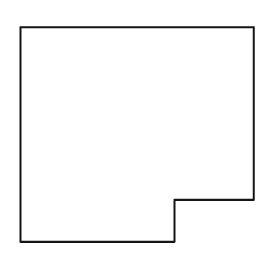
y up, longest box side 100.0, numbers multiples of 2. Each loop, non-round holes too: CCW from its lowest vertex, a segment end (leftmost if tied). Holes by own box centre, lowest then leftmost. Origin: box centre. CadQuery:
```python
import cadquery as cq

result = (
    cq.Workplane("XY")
    .moveTo(-50.0, -46.0)
    .lineTo(16.0, -46.0)
    .lineTo(16.0, -28.0)
    .lineTo(50.0, -28.0)
    .lineTo(50.0, 46.0)
    .lineTo(-50.0, 46.0)
    .close()
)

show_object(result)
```